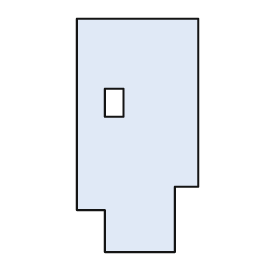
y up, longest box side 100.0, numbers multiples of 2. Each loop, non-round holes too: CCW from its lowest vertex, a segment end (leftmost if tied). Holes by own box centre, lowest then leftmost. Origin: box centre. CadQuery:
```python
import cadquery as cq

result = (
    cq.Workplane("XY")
    .moveTo(-14.0, -50.0)
    .lineTo(16.0, -50.0)
    .lineTo(16.0, -22.0)
    .lineTo(26.0, -22.0)
    .lineTo(26.0, 50.0)
    .lineTo(-26.0, 50.0)
    .lineTo(-26.0, -32.0)
    .lineTo(-14.0, -32.0)
    .close()
    .moveTo(-14.0, 8.0)
    .lineTo(-6.0, 8.0)
    .lineTo(-6.0, 20.0)
    .lineTo(-14.0, 20.0)
    .close()
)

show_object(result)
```